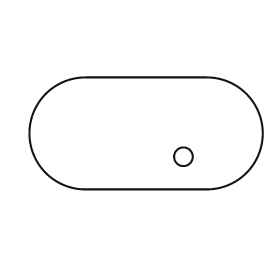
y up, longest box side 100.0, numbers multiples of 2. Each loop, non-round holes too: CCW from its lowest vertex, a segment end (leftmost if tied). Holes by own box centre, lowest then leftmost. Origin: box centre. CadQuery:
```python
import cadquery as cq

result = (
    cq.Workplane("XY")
    .moveTo(-26.0, -24.0)
    .lineTo(26.0, -24.0)
    .threePointArc((50.0, 0.0), (26.0, 24.0))
    .lineTo(-26.0, 24.0)
    .threePointArc((-50.0, 0.0), (-26.0, -24.0))
    .close()
    .moveTo(16.0, -10.0)
    .circle(4.0)
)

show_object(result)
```